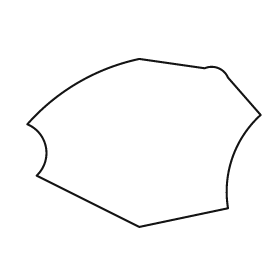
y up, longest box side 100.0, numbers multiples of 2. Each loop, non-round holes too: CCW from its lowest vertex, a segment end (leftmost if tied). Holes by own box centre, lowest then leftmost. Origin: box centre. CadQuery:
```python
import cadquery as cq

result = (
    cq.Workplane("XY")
    .moveTo(-2.0, -36.0)
    .lineTo(36.0, -28.0)
    .threePointArc((38.0, -6.0), (50.0, 12.0))
    .lineTo(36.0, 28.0)
    .threePointArc((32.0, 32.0), (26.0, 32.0))
    .lineTo(-2.0, 36.0)
    .threePointArc((-28.0, 26.0), (-50.0, 8.0))
    .threePointArc((-42.0, -2.0), (-46.0, -14.0))
    .close()
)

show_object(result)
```